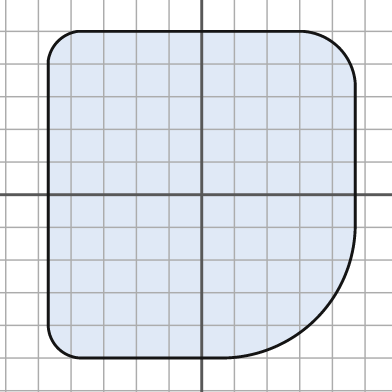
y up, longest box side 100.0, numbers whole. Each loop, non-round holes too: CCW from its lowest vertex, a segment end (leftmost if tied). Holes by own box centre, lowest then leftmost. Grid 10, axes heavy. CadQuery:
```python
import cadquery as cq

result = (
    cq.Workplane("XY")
    .moveTo(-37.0, -50.0)
    .lineTo(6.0, -50.0)
    .threePointArc((35.0, -38.0), (47.0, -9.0))
    .lineTo(47.0, 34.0)
    .threePointArc((42.0, 45.0), (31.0, 50.0))
    .lineTo(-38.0, 50.0)
    .threePointArc((-44.0, 47.0), (-47.0, 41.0))
    .lineTo(-47.0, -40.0)
    .threePointArc((-44.0, -47.0), (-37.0, -50.0))
    .close()
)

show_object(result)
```